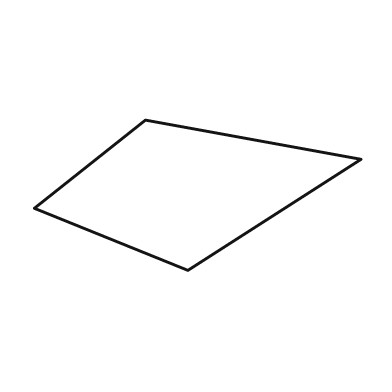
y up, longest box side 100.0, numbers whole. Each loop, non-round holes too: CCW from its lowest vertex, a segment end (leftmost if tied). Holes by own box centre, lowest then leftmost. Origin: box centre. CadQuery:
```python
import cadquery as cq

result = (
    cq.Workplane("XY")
    .moveTo(-3.0, -23.0)
    .lineTo(50.0, 11.0)
    .lineTo(-16.0, 23.0)
    .lineTo(-50.0, -4.0)
    .close()
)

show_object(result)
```